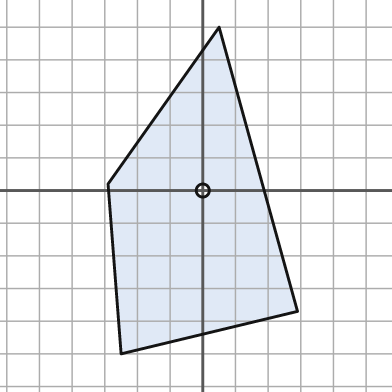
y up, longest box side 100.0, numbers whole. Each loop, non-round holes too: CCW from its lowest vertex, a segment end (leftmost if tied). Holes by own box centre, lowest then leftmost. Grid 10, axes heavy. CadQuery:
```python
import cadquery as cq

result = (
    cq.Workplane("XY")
    .moveTo(-25.0, -50.0)
    .lineTo(29.0, -37.0)
    .lineTo(5.0, 50.0)
    .lineTo(-29.0, 2.0)
    .close()
    .moveTo(0.0, 0.0)
    .circle(2.0)
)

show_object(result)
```